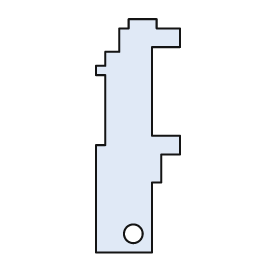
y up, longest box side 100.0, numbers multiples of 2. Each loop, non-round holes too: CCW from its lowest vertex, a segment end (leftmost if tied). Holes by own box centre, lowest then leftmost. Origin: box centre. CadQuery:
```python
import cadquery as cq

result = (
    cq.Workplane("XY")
    .moveTo(-18.0, -50.0)
    .lineTo(6.0, -50.0)
    .lineTo(6.0, -20.0)
    .lineTo(10.0, -20.0)
    .lineTo(10.0, -8.0)
    .lineTo(18.0, -8.0)
    .lineTo(18.0, 0.0)
    .lineTo(6.0, 0.0)
    .lineTo(6.0, 38.0)
    .lineTo(18.0, 38.0)
    .lineTo(18.0, 46.0)
    .lineTo(8.0, 46.0)
    .lineTo(8.0, 50.0)
    .lineTo(-4.0, 50.0)
    .lineTo(-4.0, 46.0)
    .lineTo(-8.0, 46.0)
    .lineTo(-8.0, 36.0)
    .lineTo(-14.0, 36.0)
    .lineTo(-14.0, 30.0)
    .lineTo(-18.0, 30.0)
    .lineTo(-18.0, 26.0)
    .lineTo(-14.0, 26.0)
    .lineTo(-14.0, -4.0)
    .lineTo(-18.0, -4.0)
    .close()
    .moveTo(-2.0, -42.0)
    .circle(4.0)
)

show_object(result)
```